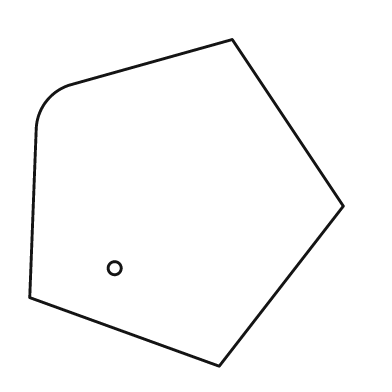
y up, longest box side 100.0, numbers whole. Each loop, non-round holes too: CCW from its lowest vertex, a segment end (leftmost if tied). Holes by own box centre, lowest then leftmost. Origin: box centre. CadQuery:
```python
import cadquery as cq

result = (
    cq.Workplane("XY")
    .moveTo(10.0, -50.0)
    .lineTo(48.0, -1.0)
    .lineTo(14.0, 50.0)
    .lineTo(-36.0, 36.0)
    .threePointArc((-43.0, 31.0), (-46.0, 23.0))
    .lineTo(-48.0, -29.0)
    .close()
    .moveTo(-22.0, -20.0)
    .circle(2.0)
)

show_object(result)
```